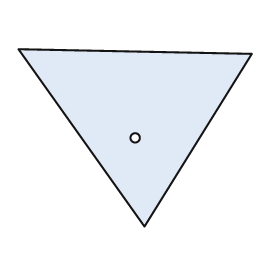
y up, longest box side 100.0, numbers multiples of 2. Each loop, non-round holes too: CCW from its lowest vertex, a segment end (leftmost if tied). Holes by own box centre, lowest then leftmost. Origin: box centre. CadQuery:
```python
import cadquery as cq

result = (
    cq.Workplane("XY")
    .moveTo(4.0, -38.0)
    .lineTo(50.0, 36.0)
    .lineTo(-50.0, 38.0)
    .close()
    .moveTo(0.0, 0.0)
    .circle(2.0)
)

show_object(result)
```